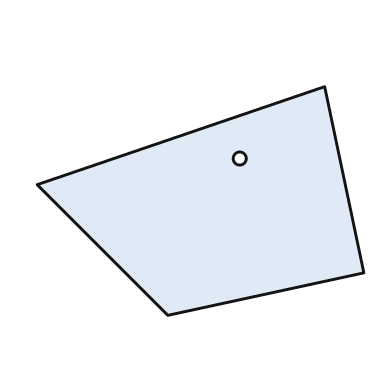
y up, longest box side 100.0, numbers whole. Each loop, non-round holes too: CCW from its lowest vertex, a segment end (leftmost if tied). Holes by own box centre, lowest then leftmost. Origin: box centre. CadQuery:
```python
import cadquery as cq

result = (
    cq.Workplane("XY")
    .moveTo(-10.0, -35.0)
    .lineTo(50.0, -22.0)
    .lineTo(38.0, 35.0)
    .lineTo(-50.0, 5.0)
    .close()
    .moveTo(12.0, 13.0)
    .circle(2.0)
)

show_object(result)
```